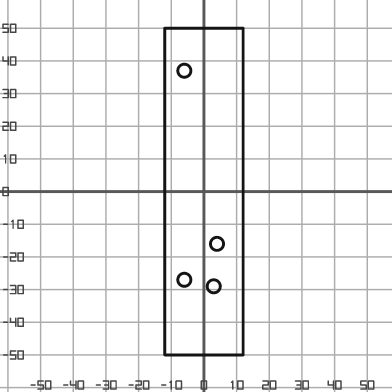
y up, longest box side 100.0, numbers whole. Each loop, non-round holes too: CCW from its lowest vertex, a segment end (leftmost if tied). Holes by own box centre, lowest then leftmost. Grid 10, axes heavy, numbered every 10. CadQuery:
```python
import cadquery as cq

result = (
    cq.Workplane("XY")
    .moveTo(-12.0, -50.0)
    .lineTo(12.0, -50.0)
    .lineTo(12.0, 50.0)
    .lineTo(-12.0, 50.0)
    .close()
    .moveTo(3.0, -29.0)
    .circle(2.0)
    .moveTo(-6.0, -27.0)
    .circle(2.0)
    .moveTo(4.0, -16.0)
    .circle(2.0)
    .moveTo(-6.0, 37.0)
    .circle(2.0)
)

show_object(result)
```